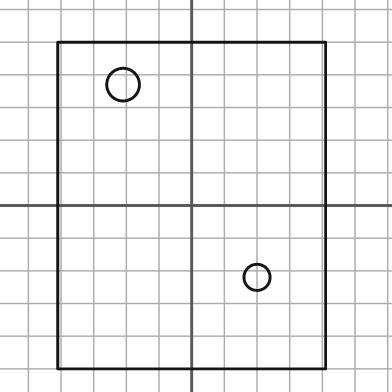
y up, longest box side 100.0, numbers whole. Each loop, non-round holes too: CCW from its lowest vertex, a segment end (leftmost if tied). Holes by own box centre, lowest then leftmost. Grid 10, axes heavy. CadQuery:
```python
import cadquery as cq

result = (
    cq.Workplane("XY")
    .moveTo(-41.0, -50.0)
    .lineTo(41.0, -50.0)
    .lineTo(41.0, 50.0)
    .lineTo(-41.0, 50.0)
    .close()
    .moveTo(20.0, -22.0)
    .circle(4.0)
    .moveTo(-21.0, 37.0)
    .circle(5.0)
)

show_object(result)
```